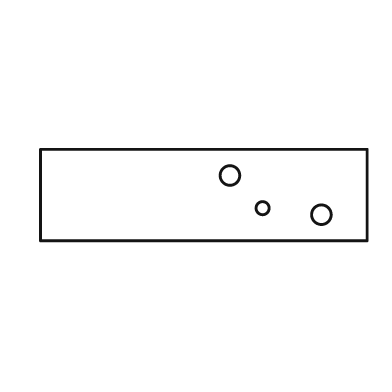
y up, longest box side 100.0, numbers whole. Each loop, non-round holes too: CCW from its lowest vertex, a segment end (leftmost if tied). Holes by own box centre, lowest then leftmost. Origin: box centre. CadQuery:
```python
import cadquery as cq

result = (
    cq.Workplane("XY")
    .moveTo(-50.0, -14.0)
    .lineTo(50.0, -14.0)
    .lineTo(50.0, 14.0)
    .lineTo(-50.0, 14.0)
    .close()
    .moveTo(36.0, -6.0)
    .circle(3.0)
    .moveTo(18.0, -4.0)
    .circle(2.0)
    .moveTo(8.0, 6.0)
    .circle(3.0)
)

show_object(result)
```